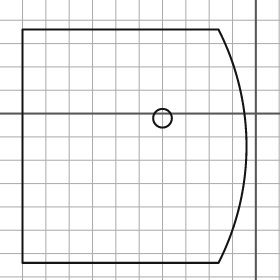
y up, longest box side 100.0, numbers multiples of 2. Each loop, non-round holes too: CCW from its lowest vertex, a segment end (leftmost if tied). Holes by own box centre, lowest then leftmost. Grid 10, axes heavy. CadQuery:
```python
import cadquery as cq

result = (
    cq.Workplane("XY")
    .moveTo(-100.0, -64.0)
    .lineTo(-16.0, -64.0)
    .threePointArc((-4.0, -14.0), (-16.0, 36.0))
    .lineTo(-100.0, 36.0)
    .close()
    .moveTo(-40.0, -2.0)
    .circle(4.0)
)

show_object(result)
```